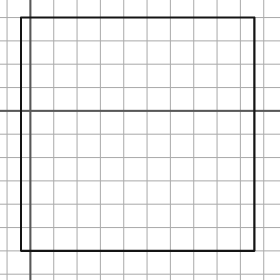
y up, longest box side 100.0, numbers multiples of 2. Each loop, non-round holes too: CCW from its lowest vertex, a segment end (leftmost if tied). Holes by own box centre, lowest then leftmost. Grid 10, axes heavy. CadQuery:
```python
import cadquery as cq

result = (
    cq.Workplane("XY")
    .moveTo(-4.0, -60.0)
    .lineTo(96.0, -60.0)
    .lineTo(96.0, 40.0)
    .lineTo(-4.0, 40.0)
    .close()
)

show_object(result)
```